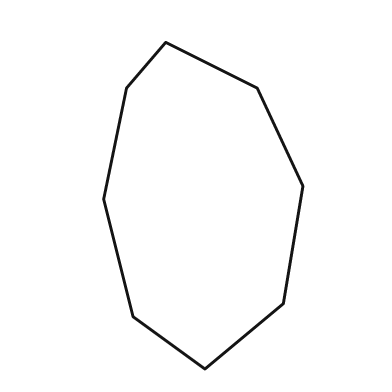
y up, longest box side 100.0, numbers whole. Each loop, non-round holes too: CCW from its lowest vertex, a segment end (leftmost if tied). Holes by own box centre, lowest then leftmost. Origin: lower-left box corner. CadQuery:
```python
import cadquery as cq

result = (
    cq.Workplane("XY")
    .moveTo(31.0, 0.0)
    .lineTo(55.0, 20.0)
    .lineTo(61.0, 56.0)
    .lineTo(47.0, 86.0)
    .lineTo(19.0, 100.0)
    .lineTo(7.0, 86.0)
    .lineTo(0.0, 52.0)
    .lineTo(9.0, 16.0)
    .close()
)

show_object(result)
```